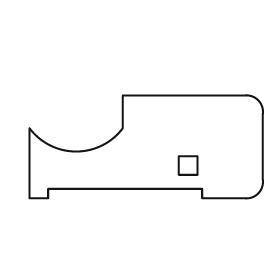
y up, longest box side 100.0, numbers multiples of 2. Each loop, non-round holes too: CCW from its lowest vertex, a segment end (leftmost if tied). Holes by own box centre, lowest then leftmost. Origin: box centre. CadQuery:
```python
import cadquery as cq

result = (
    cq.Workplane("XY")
    .moveTo(-50.0, -22.0)
    .lineTo(-42.0, -22.0)
    .lineTo(-42.0, -18.0)
    .lineTo(24.0, -18.0)
    .lineTo(24.0, -22.0)
    .lineTo(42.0, -22.0)
    .threePointArc((48.0, -20.0), (50.0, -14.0))
    .lineTo(50.0, 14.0)
    .threePointArc((48.0, 20.0), (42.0, 22.0))
    .lineTo(-10.0, 22.0)
    .lineTo(-10.0, 8.0)
    .threePointArc((-30.0, -2.0), (-50.0, 8.0))
    .close()
    .moveTo(14.0, -12.0)
    .lineTo(22.0, -12.0)
    .lineTo(22.0, -4.0)
    .lineTo(14.0, -4.0)
    .close()
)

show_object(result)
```